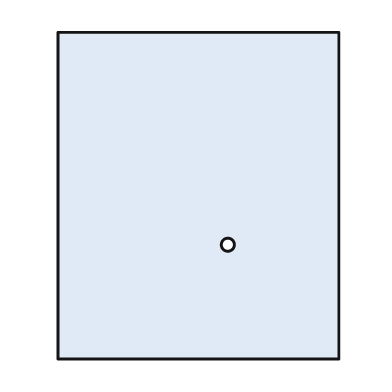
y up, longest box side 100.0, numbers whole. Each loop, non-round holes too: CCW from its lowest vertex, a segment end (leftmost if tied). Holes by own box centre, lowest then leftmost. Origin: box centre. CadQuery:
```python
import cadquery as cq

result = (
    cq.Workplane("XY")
    .moveTo(-43.0, -50.0)
    .lineTo(43.0, -50.0)
    .lineTo(43.0, 50.0)
    .lineTo(-43.0, 50.0)
    .close()
    .moveTo(9.0, -15.0)
    .circle(2.0)
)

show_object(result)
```